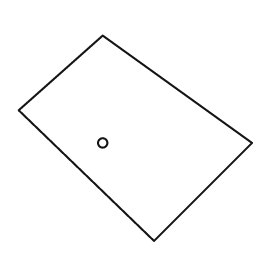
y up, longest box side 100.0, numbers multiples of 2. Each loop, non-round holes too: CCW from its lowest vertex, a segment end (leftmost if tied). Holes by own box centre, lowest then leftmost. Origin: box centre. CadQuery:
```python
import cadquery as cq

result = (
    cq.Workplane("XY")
    .moveTo(8.0, -44.0)
    .lineTo(50.0, -2.0)
    .lineTo(-14.0, 44.0)
    .lineTo(-50.0, 12.0)
    .close()
    .moveTo(-14.0, -2.0)
    .circle(2.0)
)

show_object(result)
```